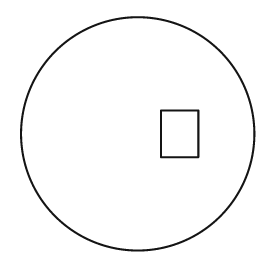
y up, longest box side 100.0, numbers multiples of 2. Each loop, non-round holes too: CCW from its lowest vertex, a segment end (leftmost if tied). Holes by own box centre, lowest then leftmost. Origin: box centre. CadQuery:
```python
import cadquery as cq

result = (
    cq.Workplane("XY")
    .moveTo(0.0, 0.0)
    .circle(50.0)
    .moveTo(10.0, -10.0)
    .lineTo(26.0, -10.0)
    .lineTo(26.0, 10.0)
    .lineTo(10.0, 10.0)
    .close()
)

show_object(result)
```